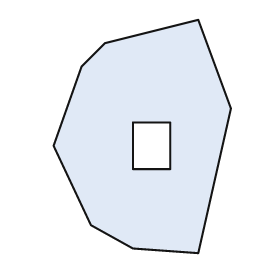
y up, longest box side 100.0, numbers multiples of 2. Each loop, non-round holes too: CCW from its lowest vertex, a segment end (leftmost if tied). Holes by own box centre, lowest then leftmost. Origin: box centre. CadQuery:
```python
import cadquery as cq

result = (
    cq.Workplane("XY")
    .moveTo(24.0, -50.0)
    .lineTo(38.0, 12.0)
    .lineTo(24.0, 50.0)
    .lineTo(-16.0, 40.0)
    .lineTo(-26.0, 30.0)
    .lineTo(-38.0, -4.0)
    .lineTo(-22.0, -38.0)
    .lineTo(-4.0, -48.0)
    .close()
    .moveTo(-4.0, -14.0)
    .lineTo(12.0, -14.0)
    .lineTo(12.0, 6.0)
    .lineTo(-4.0, 6.0)
    .close()
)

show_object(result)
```